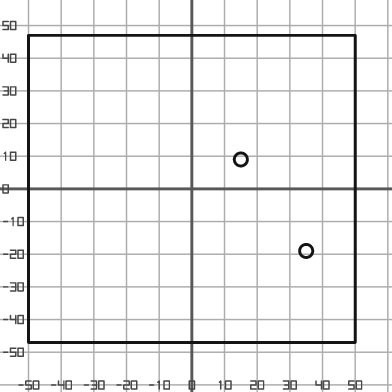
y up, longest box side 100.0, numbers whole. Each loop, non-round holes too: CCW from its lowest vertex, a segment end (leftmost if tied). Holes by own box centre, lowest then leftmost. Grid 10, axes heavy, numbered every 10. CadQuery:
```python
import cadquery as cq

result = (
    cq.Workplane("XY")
    .moveTo(-50.0, -47.0)
    .lineTo(50.0, -47.0)
    .lineTo(50.0, 47.0)
    .lineTo(-50.0, 47.0)
    .close()
    .moveTo(35.0, -19.0)
    .circle(2.0)
    .moveTo(15.0, 9.0)
    .circle(2.0)
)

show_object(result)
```